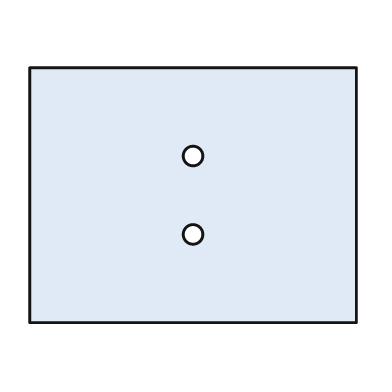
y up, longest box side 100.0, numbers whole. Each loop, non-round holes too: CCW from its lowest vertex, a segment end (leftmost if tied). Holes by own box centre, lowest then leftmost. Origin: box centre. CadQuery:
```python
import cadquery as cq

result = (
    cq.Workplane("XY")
    .moveTo(-50.0, -39.0)
    .lineTo(50.0, -39.0)
    .lineTo(50.0, 39.0)
    .lineTo(-50.0, 39.0)
    .close()
    .moveTo(0.0, -12.0)
    .circle(3.0)
    .moveTo(0.0, 12.0)
    .circle(3.0)
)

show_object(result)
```